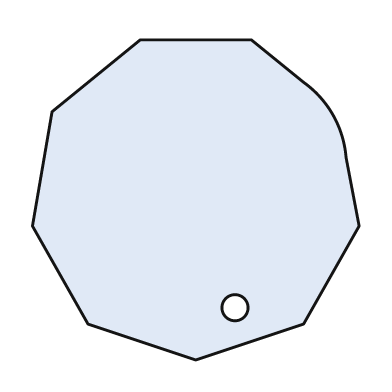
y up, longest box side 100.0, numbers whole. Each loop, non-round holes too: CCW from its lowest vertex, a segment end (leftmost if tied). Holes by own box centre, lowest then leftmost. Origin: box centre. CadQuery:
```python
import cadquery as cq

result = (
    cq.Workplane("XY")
    .moveTo(0.0, -49.0)
    .lineTo(33.0, -38.0)
    .lineTo(50.0, -8.0)
    .lineTo(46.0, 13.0)
    .threePointArc((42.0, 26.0), (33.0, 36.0))
    .lineTo(17.0, 49.0)
    .lineTo(-17.0, 49.0)
    .lineTo(-44.0, 27.0)
    .lineTo(-50.0, -8.0)
    .lineTo(-33.0, -38.0)
    .close()
    .moveTo(12.0, -33.0)
    .circle(4.0)
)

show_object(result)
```